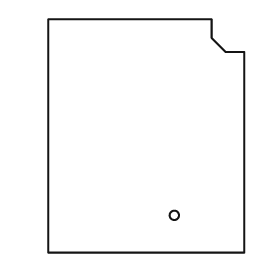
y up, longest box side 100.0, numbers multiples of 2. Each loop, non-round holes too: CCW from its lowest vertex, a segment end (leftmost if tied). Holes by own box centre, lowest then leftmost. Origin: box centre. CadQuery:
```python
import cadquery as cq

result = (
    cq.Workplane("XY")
    .moveTo(-42.0, -50.0)
    .lineTo(42.0, -50.0)
    .lineTo(42.0, 36.0)
    .lineTo(34.0, 36.0)
    .lineTo(28.0, 42.0)
    .lineTo(28.0, 50.0)
    .lineTo(-42.0, 50.0)
    .close()
    .moveTo(12.0, -34.0)
    .circle(2.0)
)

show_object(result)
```